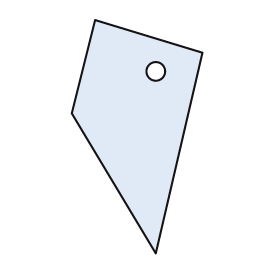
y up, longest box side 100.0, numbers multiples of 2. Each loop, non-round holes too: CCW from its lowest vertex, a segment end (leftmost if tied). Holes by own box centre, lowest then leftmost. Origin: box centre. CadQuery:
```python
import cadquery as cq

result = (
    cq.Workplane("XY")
    .moveTo(8.0, -50.0)
    .lineTo(28.0, 36.0)
    .lineTo(-18.0, 50.0)
    .lineTo(-28.0, 10.0)
    .close()
    .moveTo(8.0, 28.0)
    .circle(4.0)
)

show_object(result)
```